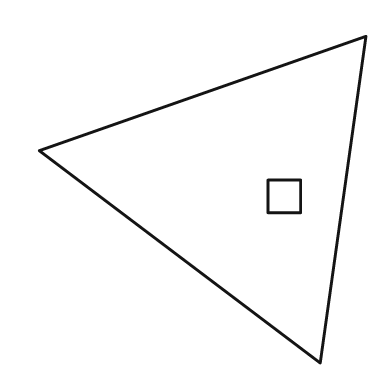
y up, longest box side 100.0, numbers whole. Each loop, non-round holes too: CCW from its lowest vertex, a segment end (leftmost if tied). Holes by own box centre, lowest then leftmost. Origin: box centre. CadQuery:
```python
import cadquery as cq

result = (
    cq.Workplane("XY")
    .moveTo(36.0, -50.0)
    .lineTo(50.0, 50.0)
    .lineTo(-50.0, 15.0)
    .close()
    .moveTo(20.0, -4.0)
    .lineTo(30.0, -4.0)
    .lineTo(30.0, 6.0)
    .lineTo(20.0, 6.0)
    .close()
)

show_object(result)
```